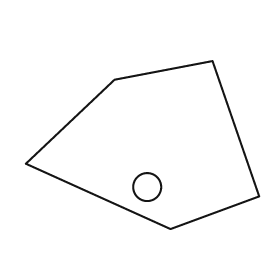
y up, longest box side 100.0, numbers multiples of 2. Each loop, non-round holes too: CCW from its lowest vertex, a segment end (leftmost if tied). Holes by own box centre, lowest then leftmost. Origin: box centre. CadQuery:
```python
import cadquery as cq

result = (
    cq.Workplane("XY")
    .moveTo(12.0, -36.0)
    .lineTo(50.0, -22.0)
    .lineTo(30.0, 36.0)
    .lineTo(-12.0, 28.0)
    .lineTo(-50.0, -8.0)
    .close()
    .moveTo(2.0, -18.0)
    .circle(6.0)
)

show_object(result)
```